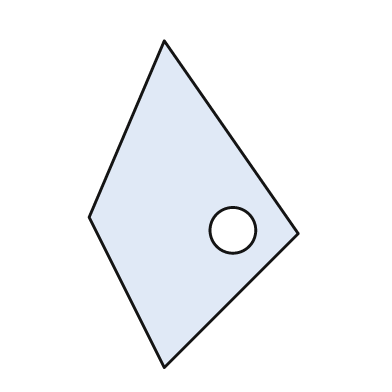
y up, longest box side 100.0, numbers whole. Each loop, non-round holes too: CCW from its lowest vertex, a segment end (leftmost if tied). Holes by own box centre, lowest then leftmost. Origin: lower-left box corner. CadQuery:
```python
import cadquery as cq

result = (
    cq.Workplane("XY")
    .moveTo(23.0, 0.0)
    .lineTo(64.0, 41.0)
    .lineTo(23.0, 100.0)
    .lineTo(0.0, 46.0)
    .close()
    .moveTo(44.0, 42.0)
    .circle(7.0)
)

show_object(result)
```